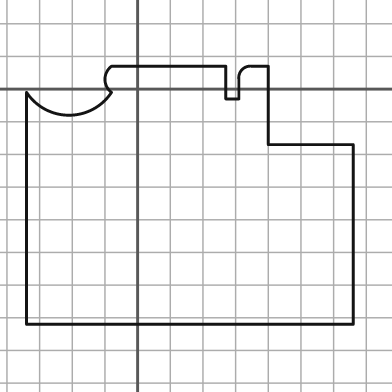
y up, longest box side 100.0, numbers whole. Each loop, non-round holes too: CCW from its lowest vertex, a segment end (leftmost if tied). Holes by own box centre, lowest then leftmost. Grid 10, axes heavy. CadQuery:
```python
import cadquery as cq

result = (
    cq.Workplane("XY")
    .moveTo(-34.0, -72.0)
    .lineTo(66.0, -72.0)
    .lineTo(66.0, -17.0)
    .lineTo(40.0, -17.0)
    .lineTo(40.0, 7.0)
    .lineTo(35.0, 7.0)
    .threePointArc((32.0, 6.0), (31.0, 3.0))
    .lineTo(31.0, -3.0)
    .lineTo(27.0, -3.0)
    .lineTo(27.0, 7.0)
    .lineTo(-8.0, 7.0)
    .threePointArc((-10.0, 3.0), (-8.0, -1.0))
    .threePointArc((-21.0, -8.0), (-34.0, -1.0))
    .close()
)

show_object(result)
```